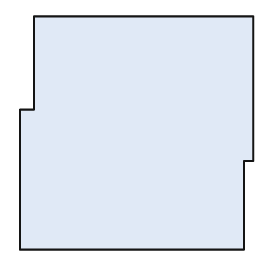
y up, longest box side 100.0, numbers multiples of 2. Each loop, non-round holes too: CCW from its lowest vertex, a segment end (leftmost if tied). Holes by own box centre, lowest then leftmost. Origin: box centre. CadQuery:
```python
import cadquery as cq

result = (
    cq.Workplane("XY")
    .moveTo(-50.0, -50.0)
    .lineTo(46.0, -50.0)
    .lineTo(46.0, -12.0)
    .lineTo(50.0, -12.0)
    .lineTo(50.0, 50.0)
    .lineTo(-44.0, 50.0)
    .lineTo(-44.0, 10.0)
    .lineTo(-50.0, 10.0)
    .close()
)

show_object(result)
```